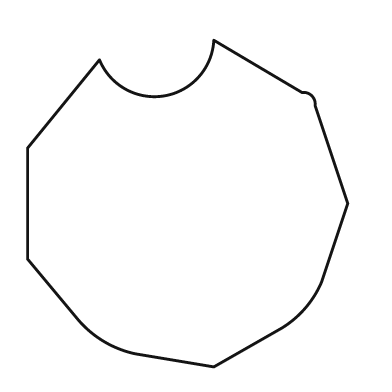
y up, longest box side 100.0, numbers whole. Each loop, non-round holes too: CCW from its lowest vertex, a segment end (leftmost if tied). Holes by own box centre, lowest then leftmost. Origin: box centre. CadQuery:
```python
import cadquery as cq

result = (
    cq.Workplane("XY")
    .moveTo(8.0, -50.0)
    .lineTo(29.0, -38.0)
    .threePointArc((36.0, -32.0), (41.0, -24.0))
    .lineTo(49.0, 0.0)
    .lineTo(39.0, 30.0)
    .threePointArc((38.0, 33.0), (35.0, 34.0))
    .lineTo(8.0, 50.0)
    .threePointArc((-7.0, 33.0), (-27.0, 44.0))
    .lineTo(-49.0, 17.0)
    .lineTo(-49.0, -17.0)
    .lineTo(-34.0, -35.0)
    .threePointArc((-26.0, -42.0), (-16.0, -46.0))
    .close()
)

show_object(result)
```